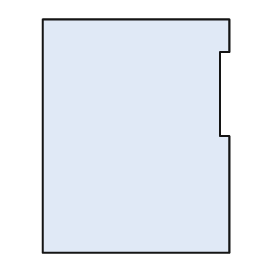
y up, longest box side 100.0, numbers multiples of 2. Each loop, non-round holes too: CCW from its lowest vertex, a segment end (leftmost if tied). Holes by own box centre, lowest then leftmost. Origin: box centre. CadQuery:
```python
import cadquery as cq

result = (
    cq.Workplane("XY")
    .moveTo(-40.0, -50.0)
    .lineTo(40.0, -50.0)
    .lineTo(40.0, 0.0)
    .lineTo(36.0, 0.0)
    .lineTo(36.0, 36.0)
    .lineTo(40.0, 36.0)
    .lineTo(40.0, 50.0)
    .lineTo(-40.0, 50.0)
    .close()
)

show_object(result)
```